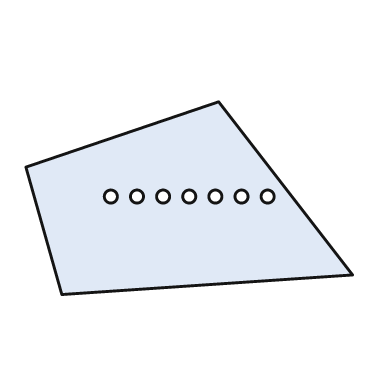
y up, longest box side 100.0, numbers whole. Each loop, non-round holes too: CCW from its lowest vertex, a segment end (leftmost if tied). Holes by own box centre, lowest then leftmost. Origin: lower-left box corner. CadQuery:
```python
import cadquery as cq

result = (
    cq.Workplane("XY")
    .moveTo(11.0, 0.0)
    .lineTo(100.0, 6.0)
    .lineTo(59.0, 59.0)
    .lineTo(0.0, 39.0)
    .close()
    .moveTo(26.0, 30.0)
    .circle(2.0)
    .moveTo(34.0, 30.0)
    .circle(2.0)
    .moveTo(42.0, 30.0)
    .circle(2.0)
    .moveTo(50.0, 30.0)
    .circle(2.0)
    .moveTo(58.0, 30.0)
    .circle(2.0)
    .moveTo(66.0, 30.0)
    .circle(2.0)
    .moveTo(74.0, 30.0)
    .circle(2.0)
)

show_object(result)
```